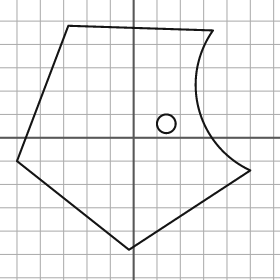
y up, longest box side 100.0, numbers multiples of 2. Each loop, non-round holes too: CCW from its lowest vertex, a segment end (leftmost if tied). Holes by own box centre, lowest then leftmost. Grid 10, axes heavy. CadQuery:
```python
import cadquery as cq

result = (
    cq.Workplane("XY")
    .moveTo(-2.0, -48.0)
    .lineTo(50.0, -14.0)
    .threePointArc((28.0, 12.0), (34.0, 46.0))
    .lineTo(-28.0, 48.0)
    .lineTo(-50.0, -10.0)
    .close()
    .moveTo(14.0, 6.0)
    .circle(4.0)
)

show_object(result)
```